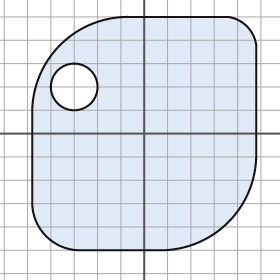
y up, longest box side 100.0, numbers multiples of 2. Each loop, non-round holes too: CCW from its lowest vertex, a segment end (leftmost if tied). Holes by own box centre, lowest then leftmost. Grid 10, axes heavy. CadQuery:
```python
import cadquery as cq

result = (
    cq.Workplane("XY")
    .moveTo(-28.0, -50.0)
    .lineTo(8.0, -50.0)
    .threePointArc((36.0, -38.0), (48.0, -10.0))
    .lineTo(48.0, 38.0)
    .threePointArc((44.0, 46.0), (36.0, 50.0))
    .lineTo(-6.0, 50.0)
    .threePointArc((-36.0, 38.0), (-48.0, 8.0))
    .lineTo(-48.0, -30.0)
    .threePointArc((-42.0, -44.0), (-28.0, -50.0))
    .close()
    .moveTo(-30.0, 20.0)
    .circle(10.0)
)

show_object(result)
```